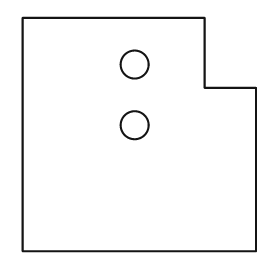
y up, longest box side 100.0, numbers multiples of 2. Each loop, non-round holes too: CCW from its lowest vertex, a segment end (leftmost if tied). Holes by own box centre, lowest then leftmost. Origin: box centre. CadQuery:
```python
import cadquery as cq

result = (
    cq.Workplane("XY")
    .moveTo(-50.0, -50.0)
    .lineTo(50.0, -50.0)
    .lineTo(50.0, 20.0)
    .lineTo(28.0, 20.0)
    .lineTo(28.0, 50.0)
    .lineTo(-50.0, 50.0)
    .close()
    .moveTo(-2.0, 4.0)
    .circle(6.0)
    .moveTo(-2.0, 30.0)
    .circle(6.0)
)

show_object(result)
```